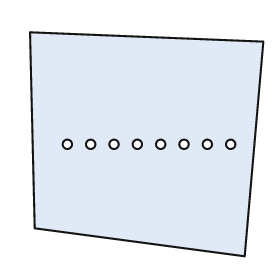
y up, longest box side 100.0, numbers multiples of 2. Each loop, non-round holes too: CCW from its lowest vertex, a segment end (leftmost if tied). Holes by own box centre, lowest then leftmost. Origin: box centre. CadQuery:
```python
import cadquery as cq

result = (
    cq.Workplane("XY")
    .moveTo(42.0, -48.0)
    .lineTo(50.0, 44.0)
    .lineTo(-50.0, 48.0)
    .lineTo(-48.0, -36.0)
    .close()
    .moveTo(-34.0, 0.0)
    .circle(2.0)
    .moveTo(-24.0, 0.0)
    .circle(2.0)
    .moveTo(-14.0, 0.0)
    .circle(2.0)
    .moveTo(-4.0, 0.0)
    .circle(2.0)
    .moveTo(6.0, 0.0)
    .circle(2.0)
    .moveTo(16.0, 0.0)
    .circle(2.0)
    .moveTo(26.0, 0.0)
    .circle(2.0)
    .moveTo(36.0, 0.0)
    .circle(2.0)
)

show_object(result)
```